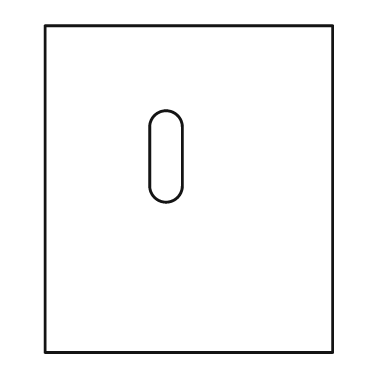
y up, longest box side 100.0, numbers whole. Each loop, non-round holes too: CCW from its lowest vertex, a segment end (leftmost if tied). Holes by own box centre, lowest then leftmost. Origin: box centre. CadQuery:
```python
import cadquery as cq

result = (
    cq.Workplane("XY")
    .moveTo(-44.0, -50.0)
    .lineTo(44.0, -50.0)
    .lineTo(44.0, 50.0)
    .lineTo(-44.0, 50.0)
    .close()
    .moveTo(-12.0, 1.0)
    .threePointArc((-7.0, -4.0), (-2.0, 1.0))
    .lineTo(-2.0, 19.0)
    .threePointArc((-7.0, 24.0), (-12.0, 19.0))
    .close()
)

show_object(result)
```